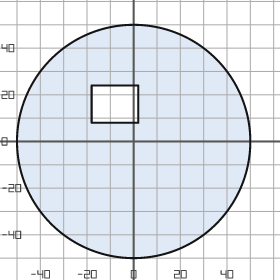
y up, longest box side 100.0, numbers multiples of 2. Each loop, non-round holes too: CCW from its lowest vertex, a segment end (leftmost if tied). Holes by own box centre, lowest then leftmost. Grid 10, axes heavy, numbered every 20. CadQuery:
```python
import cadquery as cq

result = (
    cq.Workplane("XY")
    .moveTo(0.0, 0.0)
    .circle(50.0)
    .moveTo(-18.0, 8.0)
    .lineTo(2.0, 8.0)
    .lineTo(2.0, 24.0)
    .lineTo(-18.0, 24.0)
    .close()
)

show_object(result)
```